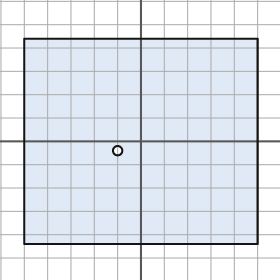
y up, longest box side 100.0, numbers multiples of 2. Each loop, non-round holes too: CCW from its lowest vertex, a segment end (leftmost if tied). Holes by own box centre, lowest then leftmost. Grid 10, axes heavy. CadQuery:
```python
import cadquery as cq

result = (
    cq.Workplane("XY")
    .moveTo(-50.0, -44.0)
    .lineTo(50.0, -44.0)
    .lineTo(50.0, 44.0)
    .lineTo(-50.0, 44.0)
    .close()
    .moveTo(-10.0, -4.0)
    .circle(2.0)
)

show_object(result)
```